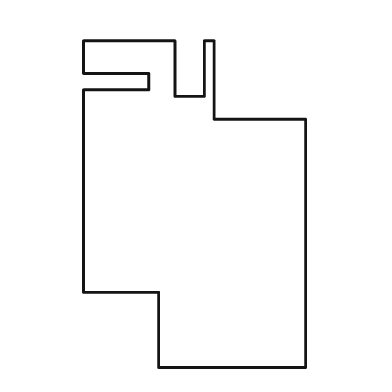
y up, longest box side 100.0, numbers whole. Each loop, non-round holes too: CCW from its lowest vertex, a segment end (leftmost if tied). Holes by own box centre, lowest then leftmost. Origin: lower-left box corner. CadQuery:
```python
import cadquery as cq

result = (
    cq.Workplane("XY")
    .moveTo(23.0, 0.0)
    .lineTo(68.0, 0.0)
    .lineTo(68.0, 76.0)
    .lineTo(40.0, 76.0)
    .lineTo(40.0, 100.0)
    .lineTo(37.0, 100.0)
    .lineTo(37.0, 83.0)
    .lineTo(28.0, 83.0)
    .lineTo(28.0, 100.0)
    .lineTo(0.0, 100.0)
    .lineTo(0.0, 90.0)
    .lineTo(20.0, 90.0)
    .lineTo(20.0, 85.0)
    .lineTo(0.0, 85.0)
    .lineTo(0.0, 23.0)
    .lineTo(23.0, 23.0)
    .close()
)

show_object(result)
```